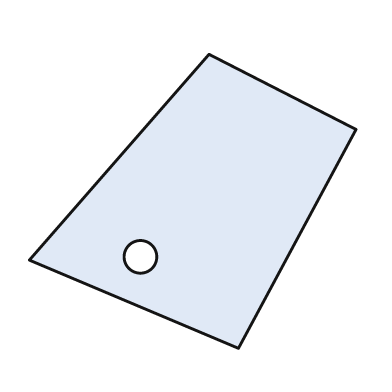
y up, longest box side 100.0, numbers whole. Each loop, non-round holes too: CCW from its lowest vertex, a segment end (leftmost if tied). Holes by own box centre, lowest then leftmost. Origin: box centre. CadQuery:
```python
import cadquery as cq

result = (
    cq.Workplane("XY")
    .moveTo(14.0, -45.0)
    .lineTo(50.0, 22.0)
    .lineTo(5.0, 45.0)
    .lineTo(-50.0, -18.0)
    .close()
    .moveTo(-16.0, -17.0)
    .circle(5.0)
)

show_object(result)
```